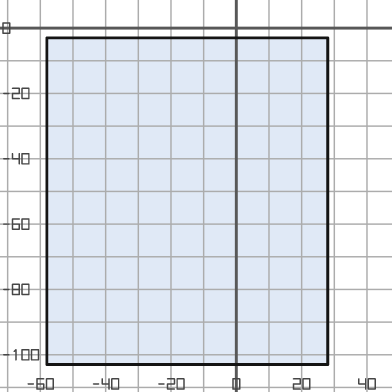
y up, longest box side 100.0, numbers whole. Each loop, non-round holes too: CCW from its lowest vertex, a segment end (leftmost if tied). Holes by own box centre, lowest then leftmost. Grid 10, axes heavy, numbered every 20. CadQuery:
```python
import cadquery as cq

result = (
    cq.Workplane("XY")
    .moveTo(-58.0, -103.0)
    .lineTo(28.0, -103.0)
    .lineTo(28.0, -3.0)
    .lineTo(-58.0, -3.0)
    .close()
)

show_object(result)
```